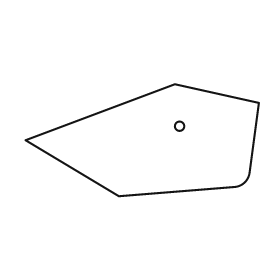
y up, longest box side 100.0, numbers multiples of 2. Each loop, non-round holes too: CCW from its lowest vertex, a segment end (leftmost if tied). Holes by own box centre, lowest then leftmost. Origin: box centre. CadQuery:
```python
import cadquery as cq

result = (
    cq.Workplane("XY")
    .moveTo(-10.0, -24.0)
    .lineTo(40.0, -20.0)
    .threePointArc((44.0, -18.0), (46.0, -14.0))
    .lineTo(50.0, 16.0)
    .lineTo(14.0, 24.0)
    .lineTo(-50.0, 0.0)
    .close()
    .moveTo(16.0, 6.0)
    .circle(2.0)
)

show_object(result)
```